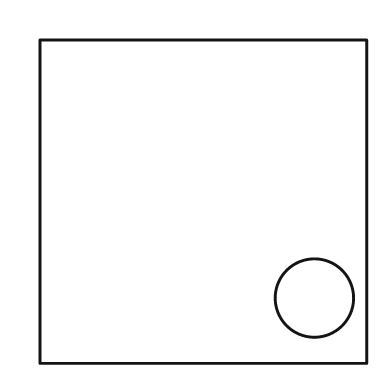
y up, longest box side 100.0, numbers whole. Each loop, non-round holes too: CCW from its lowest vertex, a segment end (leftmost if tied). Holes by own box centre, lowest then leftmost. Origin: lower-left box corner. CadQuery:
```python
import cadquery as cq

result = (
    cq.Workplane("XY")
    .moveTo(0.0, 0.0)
    .lineTo(100.0, 0.0)
    .lineTo(100.0, 99.0)
    .lineTo(0.0, 99.0)
    .close()
    .moveTo(84.0, 20.0)
    .circle(12.0)
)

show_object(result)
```